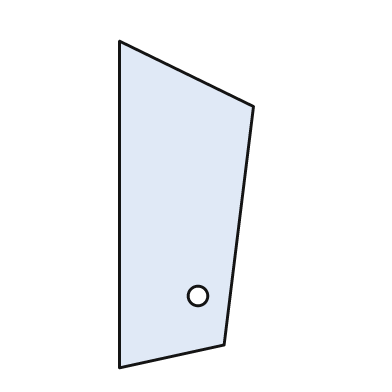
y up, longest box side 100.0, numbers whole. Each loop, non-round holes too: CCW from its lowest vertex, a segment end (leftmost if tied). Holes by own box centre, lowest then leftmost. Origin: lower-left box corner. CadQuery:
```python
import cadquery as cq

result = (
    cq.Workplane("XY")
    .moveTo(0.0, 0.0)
    .lineTo(32.0, 7.0)
    .lineTo(41.0, 80.0)
    .lineTo(0.0, 100.0)
    .close()
    .moveTo(24.0, 22.0)
    .circle(3.0)
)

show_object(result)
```